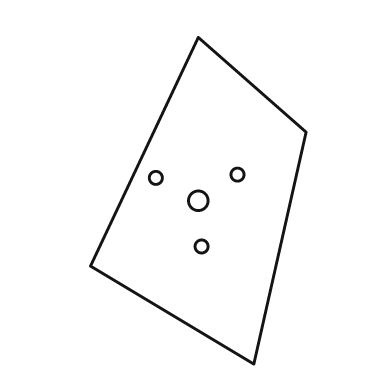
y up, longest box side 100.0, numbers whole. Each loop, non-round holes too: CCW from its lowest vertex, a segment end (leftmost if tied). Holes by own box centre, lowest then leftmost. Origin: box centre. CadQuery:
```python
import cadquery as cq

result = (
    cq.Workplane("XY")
    .moveTo(17.0, -50.0)
    .lineTo(33.0, 21.0)
    .lineTo(0.0, 50.0)
    .lineTo(-33.0, -20.0)
    .close()
    .moveTo(1.0, -14.0)
    .circle(2.0)
    .moveTo(0.0, 0.0)
    .circle(3.0)
    .moveTo(-13.0, 7.0)
    .circle(2.0)
    .moveTo(12.0, 8.0)
    .circle(2.0)
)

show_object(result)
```